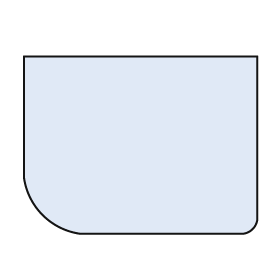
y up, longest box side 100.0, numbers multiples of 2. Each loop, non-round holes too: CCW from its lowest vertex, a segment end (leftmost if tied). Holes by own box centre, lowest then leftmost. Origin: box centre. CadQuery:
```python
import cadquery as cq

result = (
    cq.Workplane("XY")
    .moveTo(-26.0, -38.0)
    .lineTo(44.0, -38.0)
    .threePointArc((48.0, -36.0), (50.0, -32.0))
    .lineTo(50.0, 38.0)
    .lineTo(-50.0, 38.0)
    .lineTo(-50.0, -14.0)
    .threePointArc((-42.0, -30.0), (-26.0, -38.0))
    .close()
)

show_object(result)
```